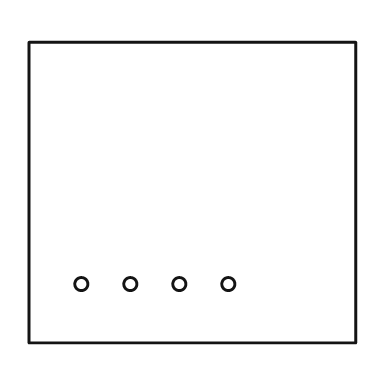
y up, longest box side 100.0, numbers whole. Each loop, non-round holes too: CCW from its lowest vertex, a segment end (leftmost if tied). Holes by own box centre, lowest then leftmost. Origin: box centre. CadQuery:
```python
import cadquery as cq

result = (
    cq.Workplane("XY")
    .moveTo(-50.0, -46.0)
    .lineTo(50.0, -46.0)
    .lineTo(50.0, 46.0)
    .lineTo(-50.0, 46.0)
    .close()
    .moveTo(-34.0, -28.0)
    .circle(2.0)
    .moveTo(-19.0, -28.0)
    .circle(2.0)
    .moveTo(-4.0, -28.0)
    .circle(2.0)
    .moveTo(11.0, -28.0)
    .circle(2.0)
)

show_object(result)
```